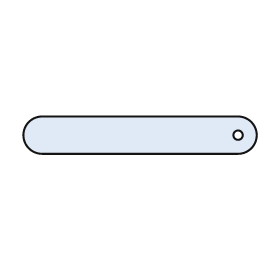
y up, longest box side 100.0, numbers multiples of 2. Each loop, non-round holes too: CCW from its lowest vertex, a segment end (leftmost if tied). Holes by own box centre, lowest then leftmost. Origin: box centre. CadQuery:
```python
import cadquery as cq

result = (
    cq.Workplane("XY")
    .moveTo(-42.0, -8.0)
    .lineTo(42.0, -8.0)
    .threePointArc((50.0, 0.0), (42.0, 8.0))
    .lineTo(-42.0, 8.0)
    .threePointArc((-50.0, 0.0), (-42.0, -8.0))
    .close()
    .moveTo(42.0, 0.0)
    .circle(2.0)
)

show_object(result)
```